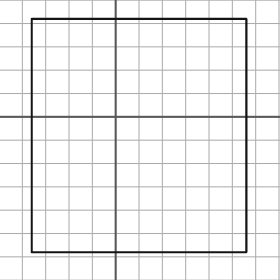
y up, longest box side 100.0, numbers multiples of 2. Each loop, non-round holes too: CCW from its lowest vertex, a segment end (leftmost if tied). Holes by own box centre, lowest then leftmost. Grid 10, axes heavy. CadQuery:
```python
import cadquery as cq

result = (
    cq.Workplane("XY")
    .moveTo(-36.0, -58.0)
    .lineTo(56.0, -58.0)
    .lineTo(56.0, 42.0)
    .lineTo(-36.0, 42.0)
    .close()
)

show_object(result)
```